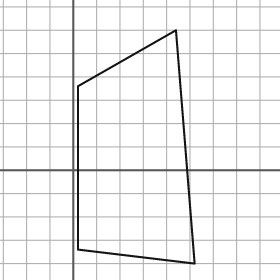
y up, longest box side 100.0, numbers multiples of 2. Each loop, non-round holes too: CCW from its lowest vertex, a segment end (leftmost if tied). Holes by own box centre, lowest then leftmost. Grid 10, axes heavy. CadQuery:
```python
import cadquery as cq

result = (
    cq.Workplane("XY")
    .moveTo(52.0, -40.0)
    .lineTo(44.0, 60.0)
    .lineTo(2.0, 36.0)
    .lineTo(2.0, -34.0)
    .close()
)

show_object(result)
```